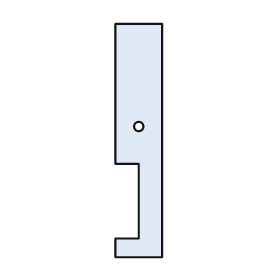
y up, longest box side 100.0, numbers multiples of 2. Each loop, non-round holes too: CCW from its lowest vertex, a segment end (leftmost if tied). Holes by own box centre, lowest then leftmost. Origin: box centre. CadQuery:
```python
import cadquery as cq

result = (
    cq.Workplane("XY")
    .moveTo(-10.0, -50.0)
    .lineTo(10.0, -50.0)
    .lineTo(10.0, 50.0)
    .lineTo(-10.0, 50.0)
    .lineTo(-10.0, -10.0)
    .lineTo(0.0, -10.0)
    .lineTo(0.0, -42.0)
    .lineTo(-10.0, -42.0)
    .close()
    .moveTo(0.0, 6.0)
    .circle(2.0)
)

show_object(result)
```